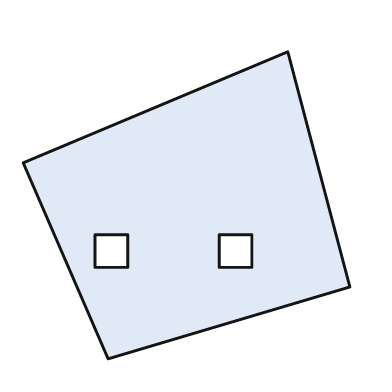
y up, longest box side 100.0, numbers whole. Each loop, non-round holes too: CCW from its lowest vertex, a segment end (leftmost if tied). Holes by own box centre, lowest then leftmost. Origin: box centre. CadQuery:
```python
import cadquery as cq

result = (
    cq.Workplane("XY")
    .moveTo(-24.0, -47.0)
    .lineTo(50.0, -25.0)
    .lineTo(31.0, 47.0)
    .lineTo(-50.0, 13.0)
    .close()
    .moveTo(-28.0, -19.0)
    .lineTo(-18.0, -19.0)
    .lineTo(-18.0, -9.0)
    .lineTo(-28.0, -9.0)
    .close()
    .moveTo(10.0, -19.0)
    .lineTo(20.0, -19.0)
    .lineTo(20.0, -9.0)
    .lineTo(10.0, -9.0)
    .close()
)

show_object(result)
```